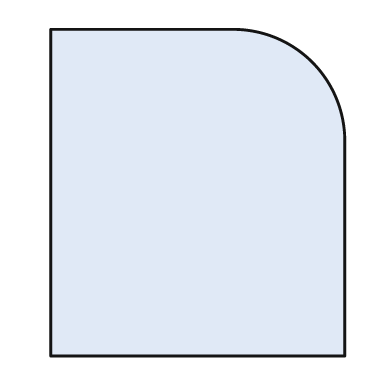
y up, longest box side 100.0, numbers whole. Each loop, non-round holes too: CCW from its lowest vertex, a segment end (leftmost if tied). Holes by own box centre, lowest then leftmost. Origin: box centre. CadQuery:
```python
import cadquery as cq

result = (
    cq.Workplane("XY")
    .moveTo(-45.0, -50.0)
    .lineTo(45.0, -50.0)
    .lineTo(45.0, 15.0)
    .threePointArc((35.0, 40.0), (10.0, 50.0))
    .lineTo(-45.0, 50.0)
    .close()
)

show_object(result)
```